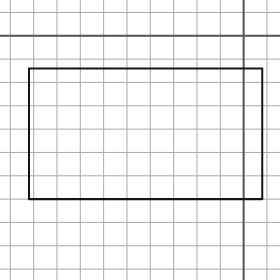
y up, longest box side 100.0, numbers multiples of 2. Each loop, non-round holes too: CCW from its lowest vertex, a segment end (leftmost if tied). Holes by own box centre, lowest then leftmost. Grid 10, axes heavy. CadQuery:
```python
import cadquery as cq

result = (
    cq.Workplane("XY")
    .moveTo(-92.0, -70.0)
    .lineTo(8.0, -70.0)
    .lineTo(8.0, -14.0)
    .lineTo(-92.0, -14.0)
    .close()
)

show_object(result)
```